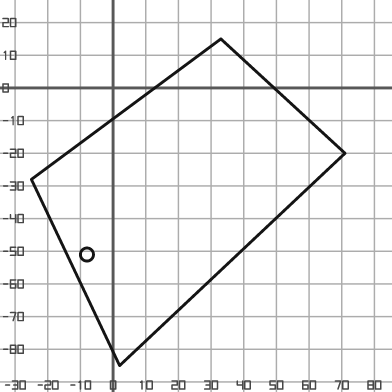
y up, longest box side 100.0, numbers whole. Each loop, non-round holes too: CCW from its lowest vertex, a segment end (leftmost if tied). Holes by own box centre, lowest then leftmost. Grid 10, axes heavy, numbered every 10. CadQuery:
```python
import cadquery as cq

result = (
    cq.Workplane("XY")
    .moveTo(2.0, -85.0)
    .lineTo(71.0, -20.0)
    .lineTo(33.0, 15.0)
    .lineTo(-25.0, -28.0)
    .close()
    .moveTo(-8.0, -51.0)
    .circle(2.0)
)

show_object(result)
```